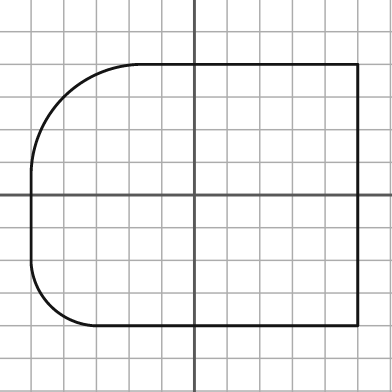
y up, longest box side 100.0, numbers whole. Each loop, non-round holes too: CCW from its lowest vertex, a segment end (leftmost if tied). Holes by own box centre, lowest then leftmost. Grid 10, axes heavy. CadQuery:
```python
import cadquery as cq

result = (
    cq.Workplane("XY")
    .moveTo(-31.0, -40.0)
    .lineTo(50.0, -40.0)
    .lineTo(50.0, 40.0)
    .lineTo(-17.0, 40.0)
    .threePointArc((-40.0, 30.0), (-50.0, 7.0))
    .lineTo(-50.0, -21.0)
    .threePointArc((-44.0, -34.0), (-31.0, -40.0))
    .close()
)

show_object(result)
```